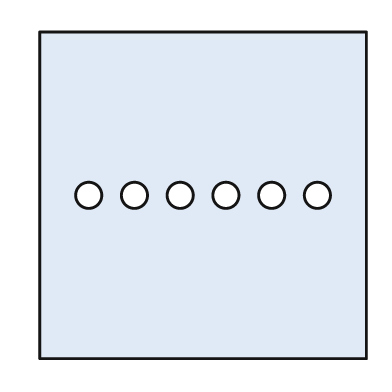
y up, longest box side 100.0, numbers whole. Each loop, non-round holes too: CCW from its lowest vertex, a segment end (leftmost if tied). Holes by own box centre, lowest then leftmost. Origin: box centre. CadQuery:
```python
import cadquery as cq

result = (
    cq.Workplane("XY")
    .moveTo(-50.0, -50.0)
    .lineTo(50.0, -50.0)
    .lineTo(50.0, 50.0)
    .lineTo(-50.0, 50.0)
    .close()
    .moveTo(-35.0, 0.0)
    .circle(4.0)
    .moveTo(-21.0, 0.0)
    .circle(4.0)
    .moveTo(-7.0, 0.0)
    .circle(4.0)
    .moveTo(7.0, 0.0)
    .circle(4.0)
    .moveTo(21.0, 0.0)
    .circle(4.0)
    .moveTo(35.0, 0.0)
    .circle(4.0)
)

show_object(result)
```